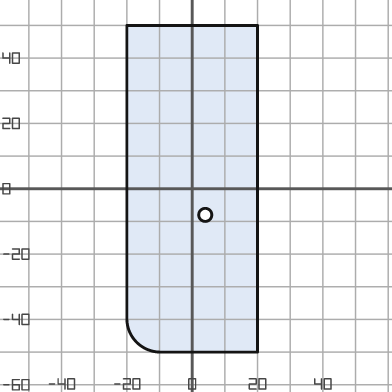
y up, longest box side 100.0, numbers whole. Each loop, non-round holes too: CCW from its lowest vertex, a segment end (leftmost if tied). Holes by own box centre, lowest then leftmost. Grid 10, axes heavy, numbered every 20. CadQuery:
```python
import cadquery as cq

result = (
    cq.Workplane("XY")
    .moveTo(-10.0, -50.0)
    .lineTo(20.0, -50.0)
    .lineTo(20.0, 50.0)
    .lineTo(-20.0, 50.0)
    .lineTo(-20.0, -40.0)
    .threePointArc((-17.0, -47.0), (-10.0, -50.0))
    .close()
    .moveTo(4.0, -8.0)
    .circle(2.0)
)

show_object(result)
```